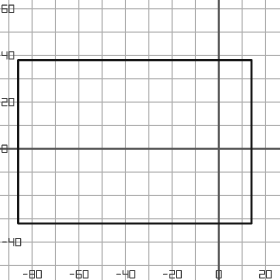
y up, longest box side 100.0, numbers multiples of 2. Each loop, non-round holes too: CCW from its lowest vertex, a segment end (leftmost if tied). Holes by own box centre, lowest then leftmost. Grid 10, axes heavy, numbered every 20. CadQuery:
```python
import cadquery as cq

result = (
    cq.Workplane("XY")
    .moveTo(-86.0, -32.0)
    .lineTo(14.0, -32.0)
    .lineTo(14.0, 38.0)
    .lineTo(-86.0, 38.0)
    .close()
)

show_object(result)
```